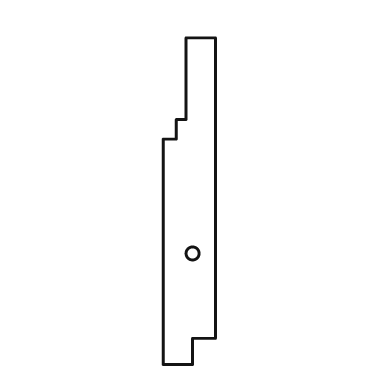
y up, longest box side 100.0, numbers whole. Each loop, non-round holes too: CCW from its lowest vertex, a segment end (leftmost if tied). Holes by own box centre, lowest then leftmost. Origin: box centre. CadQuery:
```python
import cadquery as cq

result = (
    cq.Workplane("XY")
    .moveTo(-8.0, -50.0)
    .lineTo(1.0, -50.0)
    .lineTo(1.0, -42.0)
    .lineTo(8.0, -42.0)
    .lineTo(8.0, 50.0)
    .lineTo(-1.0, 50.0)
    .lineTo(-1.0, 25.0)
    .lineTo(-4.0, 25.0)
    .lineTo(-4.0, 19.0)
    .lineTo(-8.0, 19.0)
    .close()
    .moveTo(1.0, -16.0)
    .circle(2.0)
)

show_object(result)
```